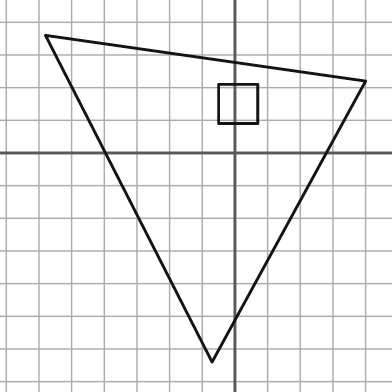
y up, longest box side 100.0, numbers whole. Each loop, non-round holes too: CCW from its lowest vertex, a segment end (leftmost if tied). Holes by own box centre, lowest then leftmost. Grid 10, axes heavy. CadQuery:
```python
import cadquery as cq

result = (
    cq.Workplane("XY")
    .moveTo(-7.0, -64.0)
    .lineTo(40.0, 22.0)
    .lineTo(-58.0, 36.0)
    .close()
    .moveTo(-5.0, 9.0)
    .lineTo(7.0, 9.0)
    .lineTo(7.0, 21.0)
    .lineTo(-5.0, 21.0)
    .close()
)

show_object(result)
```